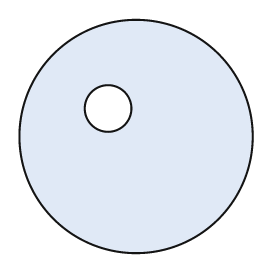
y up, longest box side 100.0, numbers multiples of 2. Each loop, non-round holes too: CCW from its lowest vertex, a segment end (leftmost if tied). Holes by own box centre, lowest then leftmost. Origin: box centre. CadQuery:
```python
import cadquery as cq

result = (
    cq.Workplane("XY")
    .moveTo(0.0, 0.0)
    .circle(50.0)
    .moveTo(-12.0, 12.0)
    .circle(10.0)
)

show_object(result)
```